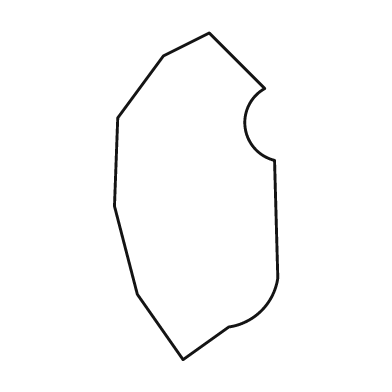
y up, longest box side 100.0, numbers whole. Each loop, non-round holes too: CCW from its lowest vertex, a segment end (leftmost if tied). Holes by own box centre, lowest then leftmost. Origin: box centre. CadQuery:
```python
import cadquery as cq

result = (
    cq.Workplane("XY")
    .moveTo(-4.0, -50.0)
    .lineTo(10.0, -40.0)
    .threePointArc((20.0, -35.0), (25.0, -25.0))
    .lineTo(24.0, 11.0)
    .threePointArc((15.0, 21.0), (21.0, 33.0))
    .lineTo(4.0, 50.0)
    .lineTo(-10.0, 43.0)
    .lineTo(-24.0, 24.0)
    .lineTo(-25.0, -3.0)
    .lineTo(-18.0, -30.0)
    .close()
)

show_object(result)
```